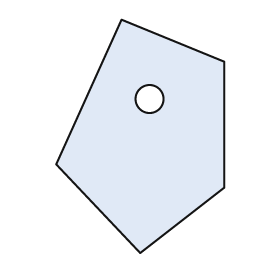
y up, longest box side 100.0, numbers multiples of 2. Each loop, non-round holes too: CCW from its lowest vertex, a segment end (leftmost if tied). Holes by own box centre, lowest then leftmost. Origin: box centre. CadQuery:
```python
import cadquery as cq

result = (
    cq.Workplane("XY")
    .moveTo(0.0, -50.0)
    .lineTo(36.0, -22.0)
    .lineTo(36.0, 32.0)
    .lineTo(-8.0, 50.0)
    .lineTo(-36.0, -12.0)
    .close()
    .moveTo(4.0, 16.0)
    .circle(6.0)
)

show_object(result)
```